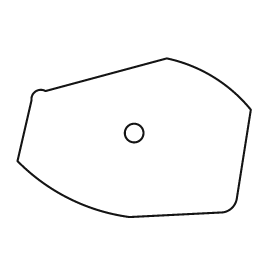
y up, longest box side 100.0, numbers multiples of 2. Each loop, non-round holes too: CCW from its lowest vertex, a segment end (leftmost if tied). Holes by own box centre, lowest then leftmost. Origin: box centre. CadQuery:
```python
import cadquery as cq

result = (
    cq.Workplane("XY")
    .moveTo(-2.0, -34.0)
    .lineTo(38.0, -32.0)
    .threePointArc((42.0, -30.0), (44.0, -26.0))
    .lineTo(50.0, 12.0)
    .threePointArc((34.0, 26.0), (14.0, 34.0))
    .lineTo(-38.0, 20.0)
    .threePointArc((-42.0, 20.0), (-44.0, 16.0))
    .lineTo(-50.0, -10.0)
    .threePointArc((-28.0, -26.0), (-2.0, -34.0))
    .close()
    .moveTo(0.0, 2.0)
    .circle(4.0)
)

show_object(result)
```